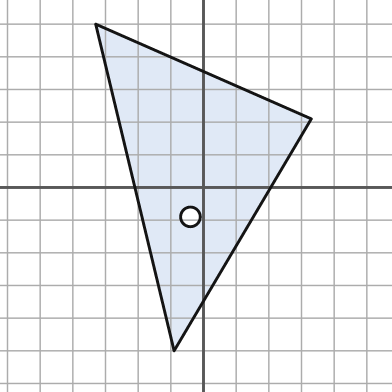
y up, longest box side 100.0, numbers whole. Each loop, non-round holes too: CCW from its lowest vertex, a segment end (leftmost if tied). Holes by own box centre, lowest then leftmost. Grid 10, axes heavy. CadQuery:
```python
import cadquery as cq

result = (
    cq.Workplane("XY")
    .moveTo(-9.0, -50.0)
    .lineTo(33.0, 21.0)
    .lineTo(-33.0, 50.0)
    .close()
    .moveTo(-4.0, -9.0)
    .circle(3.0)
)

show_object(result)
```